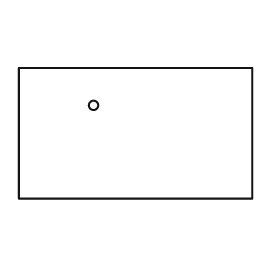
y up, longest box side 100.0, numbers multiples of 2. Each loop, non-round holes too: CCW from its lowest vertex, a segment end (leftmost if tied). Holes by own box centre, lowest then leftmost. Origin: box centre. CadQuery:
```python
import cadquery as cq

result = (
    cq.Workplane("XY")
    .moveTo(-50.0, -28.0)
    .lineTo(50.0, -28.0)
    .lineTo(50.0, 28.0)
    .lineTo(-50.0, 28.0)
    .close()
    .moveTo(-18.0, 12.0)
    .circle(2.0)
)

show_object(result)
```